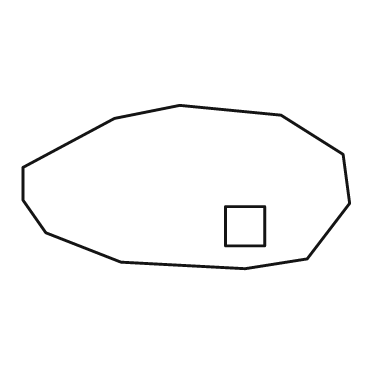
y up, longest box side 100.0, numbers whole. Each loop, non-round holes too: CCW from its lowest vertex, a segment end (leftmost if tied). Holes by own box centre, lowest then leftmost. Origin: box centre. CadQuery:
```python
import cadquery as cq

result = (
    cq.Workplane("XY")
    .moveTo(18.0, -25.0)
    .lineTo(37.0, -22.0)
    .lineTo(50.0, -5.0)
    .lineTo(48.0, 10.0)
    .lineTo(29.0, 22.0)
    .lineTo(-2.0, 25.0)
    .lineTo(-22.0, 21.0)
    .lineTo(-50.0, 6.0)
    .lineTo(-50.0, -4.0)
    .lineTo(-43.0, -14.0)
    .lineTo(-20.0, -23.0)
    .close()
    .moveTo(12.0, -18.0)
    .lineTo(24.0, -18.0)
    .lineTo(24.0, -6.0)
    .lineTo(12.0, -6.0)
    .close()
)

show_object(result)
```